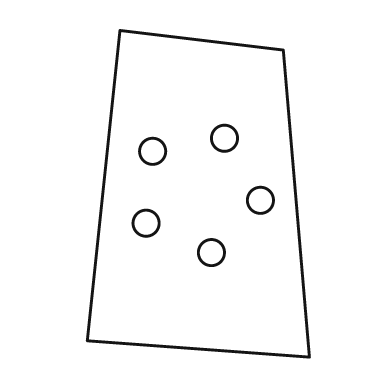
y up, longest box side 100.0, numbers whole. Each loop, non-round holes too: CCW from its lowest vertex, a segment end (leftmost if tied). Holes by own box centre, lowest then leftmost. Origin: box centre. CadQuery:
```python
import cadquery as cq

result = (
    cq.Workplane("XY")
    .moveTo(34.0, -50.0)
    .lineTo(26.0, 44.0)
    .lineTo(-24.0, 50.0)
    .lineTo(-34.0, -45.0)
    .close()
    .moveTo(4.0, -18.0)
    .circle(4.0)
    .moveTo(-16.0, -9.0)
    .circle(4.0)
    .moveTo(19.0, -2.0)
    .circle(4.0)
    .moveTo(-14.0, 13.0)
    .circle(4.0)
    .moveTo(8.0, 17.0)
    .circle(4.0)
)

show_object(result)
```